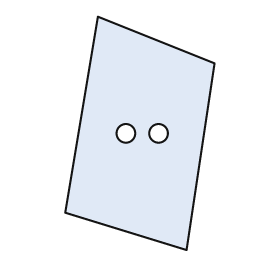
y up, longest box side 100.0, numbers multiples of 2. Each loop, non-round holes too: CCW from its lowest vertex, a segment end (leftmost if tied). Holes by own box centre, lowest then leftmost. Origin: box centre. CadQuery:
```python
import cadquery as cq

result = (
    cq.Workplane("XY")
    .moveTo(20.0, -50.0)
    .lineTo(32.0, 30.0)
    .lineTo(-18.0, 50.0)
    .lineTo(-32.0, -34.0)
    .close()
    .moveTo(-6.0, 0.0)
    .circle(4.0)
    .moveTo(8.0, 0.0)
    .circle(4.0)
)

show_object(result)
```